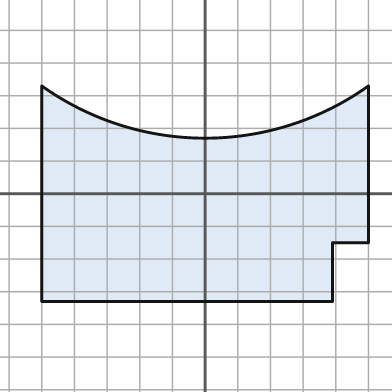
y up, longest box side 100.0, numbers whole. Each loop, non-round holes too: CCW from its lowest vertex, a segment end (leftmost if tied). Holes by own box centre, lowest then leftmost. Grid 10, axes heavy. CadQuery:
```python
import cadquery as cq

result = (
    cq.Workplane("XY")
    .moveTo(-50.0, -33.0)
    .lineTo(39.0, -33.0)
    .lineTo(39.0, -15.0)
    .lineTo(50.0, -15.0)
    .lineTo(50.0, 33.0)
    .threePointArc((0.0, 17.0), (-50.0, 33.0))
    .close()
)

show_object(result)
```